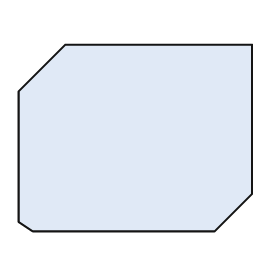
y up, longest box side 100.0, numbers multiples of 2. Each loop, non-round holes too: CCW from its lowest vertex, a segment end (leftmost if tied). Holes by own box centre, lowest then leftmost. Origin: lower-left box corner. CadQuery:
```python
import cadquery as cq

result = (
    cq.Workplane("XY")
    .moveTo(6.0, 0.0)
    .lineTo(84.0, 0.0)
    .lineTo(100.0, 16.0)
    .lineTo(100.0, 80.0)
    .lineTo(20.0, 80.0)
    .lineTo(0.0, 60.0)
    .lineTo(0.0, 4.0)
    .close()
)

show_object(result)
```